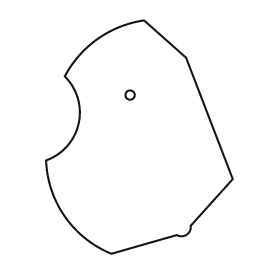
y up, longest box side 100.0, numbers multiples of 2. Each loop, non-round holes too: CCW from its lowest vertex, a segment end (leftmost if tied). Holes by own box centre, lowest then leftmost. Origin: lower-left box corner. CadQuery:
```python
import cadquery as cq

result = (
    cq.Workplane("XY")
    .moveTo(28.0, 0.0)
    .lineTo(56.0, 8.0)
    .threePointArc((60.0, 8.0), (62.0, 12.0))
    .lineTo(80.0, 32.0)
    .lineTo(60.0, 84.0)
    .lineTo(42.0, 100.0)
    .threePointArc((22.0, 92.0), (8.0, 76.0))
    .threePointArc((14.0, 56.0), (0.0, 40.0))
    .threePointArc((8.0, 16.0), (28.0, 0.0))
    .close()
    .moveTo(36.0, 68.0)
    .circle(2.0)
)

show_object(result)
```